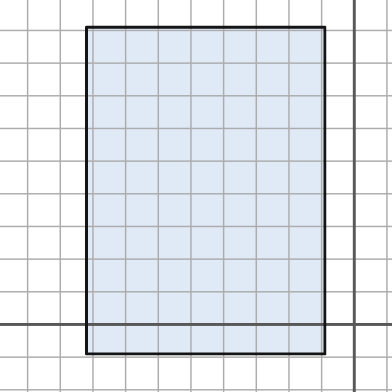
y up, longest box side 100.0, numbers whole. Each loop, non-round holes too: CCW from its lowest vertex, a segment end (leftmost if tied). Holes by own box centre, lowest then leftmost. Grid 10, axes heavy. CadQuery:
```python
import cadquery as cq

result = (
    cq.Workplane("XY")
    .moveTo(-82.0, -9.0)
    .lineTo(-9.0, -9.0)
    .lineTo(-9.0, 91.0)
    .lineTo(-82.0, 91.0)
    .close()
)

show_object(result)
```